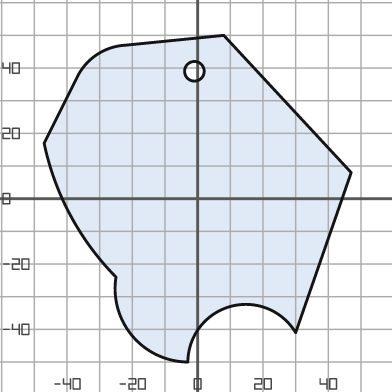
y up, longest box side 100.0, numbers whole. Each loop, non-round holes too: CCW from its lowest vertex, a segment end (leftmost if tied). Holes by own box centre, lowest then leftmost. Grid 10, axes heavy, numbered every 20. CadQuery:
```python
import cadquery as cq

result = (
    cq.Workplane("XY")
    .moveTo(-3.0, -50.0)
    .threePointArc((10.0, -33.0), (30.0, -41.0))
    .lineTo(47.0, 8.0)
    .lineTo(8.0, 50.0)
    .lineTo(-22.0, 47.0)
    .threePointArc((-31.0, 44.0), (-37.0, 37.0))
    .lineTo(-47.0, 17.0)
    .threePointArc((-39.0, -5.0), (-25.0, -24.0))
    .threePointArc((-20.0, -42.0), (-3.0, -50.0))
    .close()
    .moveTo(-1.0, 39.0)
    .circle(3.0)
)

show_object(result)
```